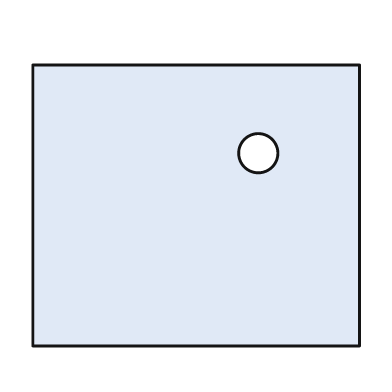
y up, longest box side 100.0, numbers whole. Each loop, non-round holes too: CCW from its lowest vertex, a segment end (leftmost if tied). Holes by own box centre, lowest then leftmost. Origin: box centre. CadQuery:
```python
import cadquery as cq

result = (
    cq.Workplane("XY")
    .moveTo(-50.0, -43.0)
    .lineTo(50.0, -43.0)
    .lineTo(50.0, 43.0)
    .lineTo(-50.0, 43.0)
    .close()
    .moveTo(19.0, 16.0)
    .circle(6.0)
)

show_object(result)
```